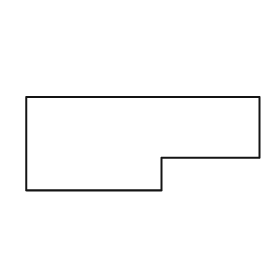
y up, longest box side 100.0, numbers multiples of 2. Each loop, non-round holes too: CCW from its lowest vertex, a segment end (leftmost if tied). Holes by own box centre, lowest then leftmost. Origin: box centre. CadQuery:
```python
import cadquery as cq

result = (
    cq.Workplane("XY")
    .moveTo(-50.0, -20.0)
    .lineTo(8.0, -20.0)
    .lineTo(8.0, -6.0)
    .lineTo(50.0, -6.0)
    .lineTo(50.0, 20.0)
    .lineTo(-50.0, 20.0)
    .close()
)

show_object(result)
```